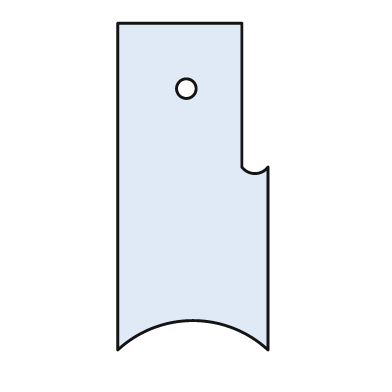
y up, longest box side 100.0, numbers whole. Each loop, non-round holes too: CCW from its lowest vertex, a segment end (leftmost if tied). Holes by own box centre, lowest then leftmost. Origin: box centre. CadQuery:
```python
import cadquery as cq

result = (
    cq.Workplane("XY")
    .moveTo(-23.0, -50.0)
    .threePointArc((0.0, -41.0), (23.0, -50.0))
    .lineTo(23.0, 6.0)
    .threePointArc((19.0, 4.0), (15.0, 6.0))
    .lineTo(15.0, 50.0)
    .lineTo(-23.0, 50.0)
    .close()
    .moveTo(-2.0, 30.0)
    .circle(3.0)
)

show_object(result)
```